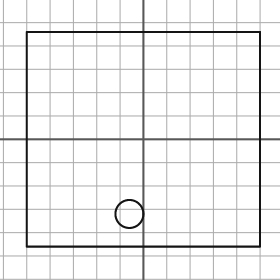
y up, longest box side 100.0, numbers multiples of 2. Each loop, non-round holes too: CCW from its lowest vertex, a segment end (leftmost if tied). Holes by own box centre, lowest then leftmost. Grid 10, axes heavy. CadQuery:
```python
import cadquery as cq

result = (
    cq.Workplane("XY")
    .moveTo(-50.0, -46.0)
    .lineTo(50.0, -46.0)
    .lineTo(50.0, 46.0)
    .lineTo(-50.0, 46.0)
    .close()
    .moveTo(-6.0, -32.0)
    .circle(6.0)
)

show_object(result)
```